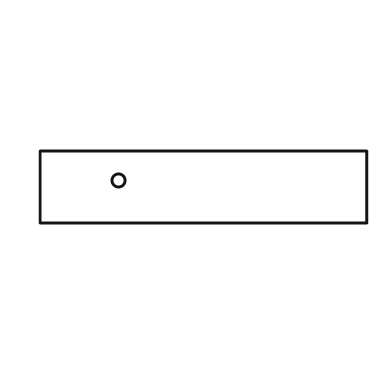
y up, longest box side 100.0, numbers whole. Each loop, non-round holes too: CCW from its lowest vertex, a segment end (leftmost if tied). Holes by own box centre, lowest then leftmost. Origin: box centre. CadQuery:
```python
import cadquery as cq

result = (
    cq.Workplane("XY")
    .moveTo(-50.0, -11.0)
    .lineTo(50.0, -11.0)
    .lineTo(50.0, 11.0)
    .lineTo(-50.0, 11.0)
    .close()
    .moveTo(-26.0, 2.0)
    .circle(2.0)
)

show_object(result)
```